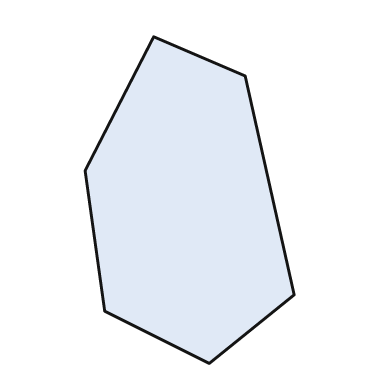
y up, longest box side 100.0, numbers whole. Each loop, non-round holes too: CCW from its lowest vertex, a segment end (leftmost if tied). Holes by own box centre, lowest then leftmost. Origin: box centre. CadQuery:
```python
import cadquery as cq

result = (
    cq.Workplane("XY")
    .moveTo(6.0, -50.0)
    .lineTo(32.0, -29.0)
    .lineTo(17.0, 38.0)
    .lineTo(-11.0, 50.0)
    .lineTo(-32.0, 9.0)
    .lineTo(-26.0, -34.0)
    .close()
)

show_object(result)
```